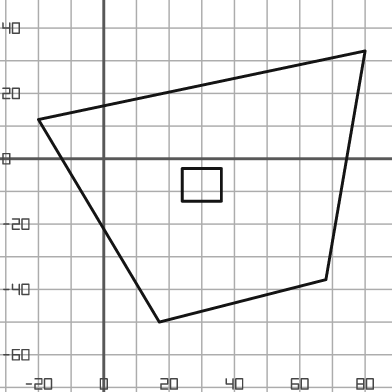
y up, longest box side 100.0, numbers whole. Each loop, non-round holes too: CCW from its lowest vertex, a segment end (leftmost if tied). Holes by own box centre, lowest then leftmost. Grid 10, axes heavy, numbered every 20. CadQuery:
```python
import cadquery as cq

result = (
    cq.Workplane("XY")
    .moveTo(17.0, -50.0)
    .lineTo(68.0, -37.0)
    .lineTo(80.0, 33.0)
    .lineTo(-20.0, 12.0)
    .close()
    .moveTo(24.0, -13.0)
    .lineTo(36.0, -13.0)
    .lineTo(36.0, -3.0)
    .lineTo(24.0, -3.0)
    .close()
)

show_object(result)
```